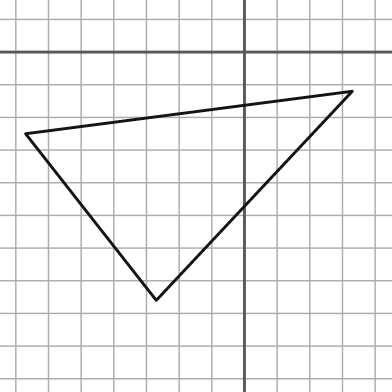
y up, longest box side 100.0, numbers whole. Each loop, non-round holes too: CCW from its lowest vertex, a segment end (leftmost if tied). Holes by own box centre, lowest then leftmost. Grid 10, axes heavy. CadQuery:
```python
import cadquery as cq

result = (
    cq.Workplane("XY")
    .moveTo(-27.0, -76.0)
    .lineTo(33.0, -12.0)
    .lineTo(-67.0, -25.0)
    .close()
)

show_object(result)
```